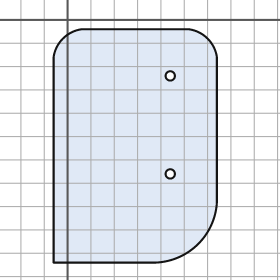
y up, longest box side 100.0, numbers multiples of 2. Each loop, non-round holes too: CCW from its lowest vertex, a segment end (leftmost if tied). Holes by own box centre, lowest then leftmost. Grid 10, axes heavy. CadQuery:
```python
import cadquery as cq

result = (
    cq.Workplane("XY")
    .moveTo(-6.0, -104.0)
    .lineTo(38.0, -104.0)
    .threePointArc((56.0, -96.0), (64.0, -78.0))
    .lineTo(64.0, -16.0)
    .threePointArc((60.0, -8.0), (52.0, -4.0))
    .lineTo(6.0, -4.0)
    .threePointArc((-2.0, -8.0), (-6.0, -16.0))
    .close()
    .moveTo(44.0, -66.0)
    .circle(2.0)
    .moveTo(44.0, -24.0)
    .circle(2.0)
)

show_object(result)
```